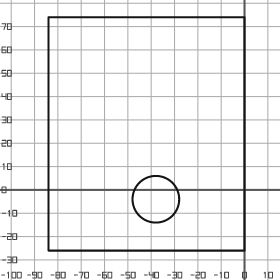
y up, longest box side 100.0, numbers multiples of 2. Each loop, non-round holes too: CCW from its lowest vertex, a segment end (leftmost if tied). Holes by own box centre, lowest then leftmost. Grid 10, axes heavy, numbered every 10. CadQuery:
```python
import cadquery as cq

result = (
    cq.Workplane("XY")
    .moveTo(-84.0, -26.0)
    .lineTo(0.0, -26.0)
    .lineTo(0.0, 74.0)
    .lineTo(-84.0, 74.0)
    .close()
    .moveTo(-38.0, -4.0)
    .circle(10.0)
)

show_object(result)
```